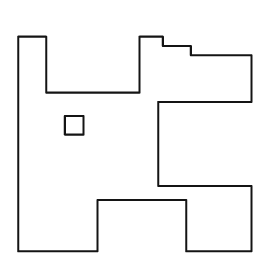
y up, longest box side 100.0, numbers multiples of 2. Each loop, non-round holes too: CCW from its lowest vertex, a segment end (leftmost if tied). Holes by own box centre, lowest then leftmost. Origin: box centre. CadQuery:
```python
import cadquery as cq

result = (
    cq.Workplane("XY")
    .moveTo(-50.0, -46.0)
    .lineTo(-16.0, -46.0)
    .lineTo(-16.0, -24.0)
    .lineTo(22.0, -24.0)
    .lineTo(22.0, -46.0)
    .lineTo(50.0, -46.0)
    .lineTo(50.0, -18.0)
    .lineTo(10.0, -18.0)
    .lineTo(10.0, 18.0)
    .lineTo(50.0, 18.0)
    .lineTo(50.0, 38.0)
    .lineTo(24.0, 38.0)
    .lineTo(24.0, 42.0)
    .lineTo(12.0, 42.0)
    .lineTo(12.0, 46.0)
    .lineTo(2.0, 46.0)
    .lineTo(2.0, 22.0)
    .lineTo(-38.0, 22.0)
    .lineTo(-38.0, 46.0)
    .lineTo(-50.0, 46.0)
    .close()
    .moveTo(-30.0, 4.0)
    .lineTo(-22.0, 4.0)
    .lineTo(-22.0, 12.0)
    .lineTo(-30.0, 12.0)
    .close()
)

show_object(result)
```